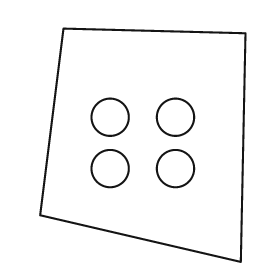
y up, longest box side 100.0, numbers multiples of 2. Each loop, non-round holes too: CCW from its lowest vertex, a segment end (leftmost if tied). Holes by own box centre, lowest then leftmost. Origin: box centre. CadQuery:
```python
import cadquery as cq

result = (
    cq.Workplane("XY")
    .moveTo(42.0, -50.0)
    .lineTo(44.0, 48.0)
    .lineTo(-34.0, 50.0)
    .lineTo(-44.0, -30.0)
    .close()
    .moveTo(-14.0, -10.0)
    .circle(8.0)
    .moveTo(14.0, -10.0)
    .circle(8.0)
    .moveTo(-14.0, 12.0)
    .circle(8.0)
    .moveTo(14.0, 12.0)
    .circle(8.0)
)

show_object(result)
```